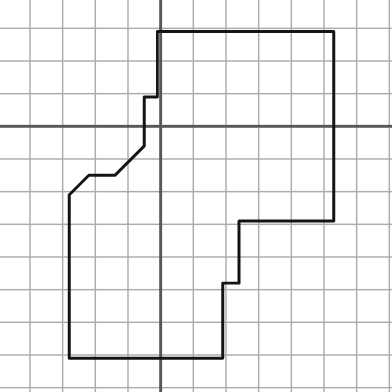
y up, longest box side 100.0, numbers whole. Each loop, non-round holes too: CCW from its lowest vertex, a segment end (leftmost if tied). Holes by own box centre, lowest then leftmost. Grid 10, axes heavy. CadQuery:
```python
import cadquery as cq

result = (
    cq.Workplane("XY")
    .moveTo(-28.0, -71.0)
    .lineTo(19.0, -71.0)
    .lineTo(19.0, -48.0)
    .lineTo(24.0, -48.0)
    .lineTo(24.0, -29.0)
    .lineTo(53.0, -29.0)
    .lineTo(53.0, 29.0)
    .lineTo(-1.0, 29.0)
    .lineTo(-1.0, 9.0)
    .lineTo(-5.0, 9.0)
    .lineTo(-5.0, -6.0)
    .lineTo(-14.0, -15.0)
    .lineTo(-22.0, -15.0)
    .lineTo(-28.0, -21.0)
    .close()
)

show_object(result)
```